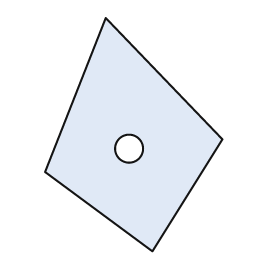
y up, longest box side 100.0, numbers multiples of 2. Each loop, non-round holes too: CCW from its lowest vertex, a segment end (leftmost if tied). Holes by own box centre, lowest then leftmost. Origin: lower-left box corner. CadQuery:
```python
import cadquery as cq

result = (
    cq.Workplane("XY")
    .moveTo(46.0, 0.0)
    .lineTo(76.0, 48.0)
    .lineTo(26.0, 100.0)
    .lineTo(0.0, 34.0)
    .close()
    .moveTo(36.0, 44.0)
    .circle(6.0)
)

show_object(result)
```